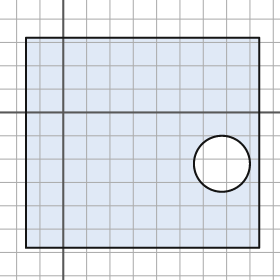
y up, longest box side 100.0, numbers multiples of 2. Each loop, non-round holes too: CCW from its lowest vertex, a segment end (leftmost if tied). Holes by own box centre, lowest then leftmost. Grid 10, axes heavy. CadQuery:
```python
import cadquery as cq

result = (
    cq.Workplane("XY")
    .moveTo(-16.0, -58.0)
    .lineTo(84.0, -58.0)
    .lineTo(84.0, 32.0)
    .lineTo(-16.0, 32.0)
    .close()
    .moveTo(68.0, -22.0)
    .circle(12.0)
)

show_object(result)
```